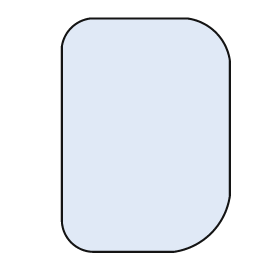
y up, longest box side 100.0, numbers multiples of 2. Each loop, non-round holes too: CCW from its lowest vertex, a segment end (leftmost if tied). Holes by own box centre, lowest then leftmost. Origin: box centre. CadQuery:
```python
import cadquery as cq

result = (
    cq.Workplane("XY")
    .moveTo(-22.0, -50.0)
    .lineTo(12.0, -50.0)
    .threePointArc((28.0, -42.0), (36.0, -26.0))
    .lineTo(36.0, 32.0)
    .threePointArc((30.0, 44.0), (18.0, 50.0))
    .lineTo(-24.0, 50.0)
    .threePointArc((-32.0, 46.0), (-36.0, 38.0))
    .lineTo(-36.0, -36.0)
    .threePointArc((-32.0, -46.0), (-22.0, -50.0))
    .close()
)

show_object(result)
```